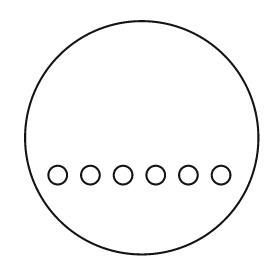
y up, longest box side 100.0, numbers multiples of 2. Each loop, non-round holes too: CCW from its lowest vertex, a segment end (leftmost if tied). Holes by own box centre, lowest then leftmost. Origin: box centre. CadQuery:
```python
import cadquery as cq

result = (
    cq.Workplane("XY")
    .moveTo(0.0, 0.0)
    .circle(50.0)
    .moveTo(-36.0, -16.0)
    .circle(4.0)
    .moveTo(-22.0, -16.0)
    .circle(4.0)
    .moveTo(-8.0, -16.0)
    .circle(4.0)
    .moveTo(6.0, -16.0)
    .circle(4.0)
    .moveTo(20.0, -16.0)
    .circle(4.0)
    .moveTo(34.0, -16.0)
    .circle(4.0)
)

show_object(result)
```